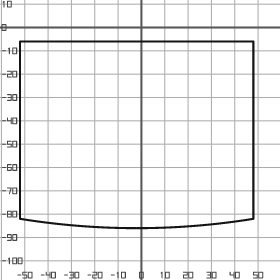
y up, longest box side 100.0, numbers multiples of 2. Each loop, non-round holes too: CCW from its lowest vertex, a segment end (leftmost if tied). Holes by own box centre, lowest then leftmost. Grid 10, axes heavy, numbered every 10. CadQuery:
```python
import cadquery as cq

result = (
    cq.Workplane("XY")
    .moveTo(-52.0, -82.0)
    .threePointArc((-2.0, -86.0), (48.0, -82.0))
    .lineTo(48.0, -6.0)
    .lineTo(-52.0, -6.0)
    .close()
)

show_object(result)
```